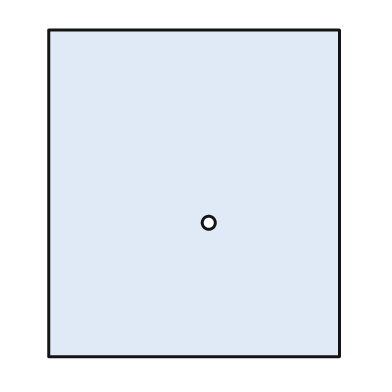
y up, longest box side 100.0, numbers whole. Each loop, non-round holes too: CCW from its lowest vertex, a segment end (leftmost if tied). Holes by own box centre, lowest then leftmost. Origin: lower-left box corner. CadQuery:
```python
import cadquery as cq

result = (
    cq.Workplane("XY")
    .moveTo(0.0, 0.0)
    .lineTo(89.0, 0.0)
    .lineTo(89.0, 100.0)
    .lineTo(0.0, 100.0)
    .close()
    .moveTo(49.0, 41.0)
    .circle(2.0)
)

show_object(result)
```